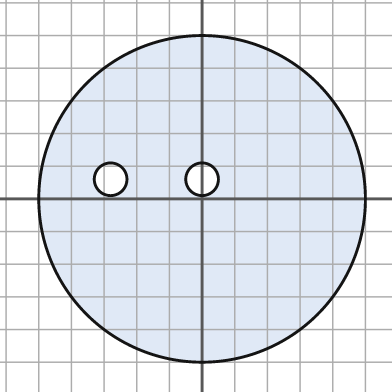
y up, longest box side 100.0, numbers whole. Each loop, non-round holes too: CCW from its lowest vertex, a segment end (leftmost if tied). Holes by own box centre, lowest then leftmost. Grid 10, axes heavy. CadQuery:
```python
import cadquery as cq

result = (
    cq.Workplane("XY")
    .moveTo(0.0, 0.0)
    .circle(50.0)
    .moveTo(-28.0, 6.0)
    .circle(5.0)
    .moveTo(0.0, 6.0)
    .circle(5.0)
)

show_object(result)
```